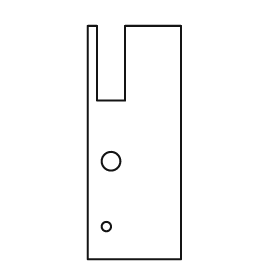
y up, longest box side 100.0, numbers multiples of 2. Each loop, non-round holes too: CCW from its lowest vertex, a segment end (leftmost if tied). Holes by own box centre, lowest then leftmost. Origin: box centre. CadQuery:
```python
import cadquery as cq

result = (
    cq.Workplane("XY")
    .moveTo(-20.0, -50.0)
    .lineTo(20.0, -50.0)
    .lineTo(20.0, 50.0)
    .lineTo(-4.0, 50.0)
    .lineTo(-4.0, 18.0)
    .lineTo(-16.0, 18.0)
    .lineTo(-16.0, 50.0)
    .lineTo(-20.0, 50.0)
    .close()
    .moveTo(-12.0, -36.0)
    .circle(2.0)
    .moveTo(-10.0, -8.0)
    .circle(4.0)
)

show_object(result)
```